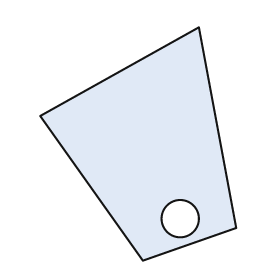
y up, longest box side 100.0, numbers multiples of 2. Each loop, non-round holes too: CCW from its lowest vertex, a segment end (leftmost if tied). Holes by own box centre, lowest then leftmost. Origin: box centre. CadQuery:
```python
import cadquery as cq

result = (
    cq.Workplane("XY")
    .moveTo(2.0, -50.0)
    .lineTo(42.0, -36.0)
    .lineTo(26.0, 50.0)
    .lineTo(-42.0, 12.0)
    .close()
    .moveTo(18.0, -32.0)
    .circle(8.0)
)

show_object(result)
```